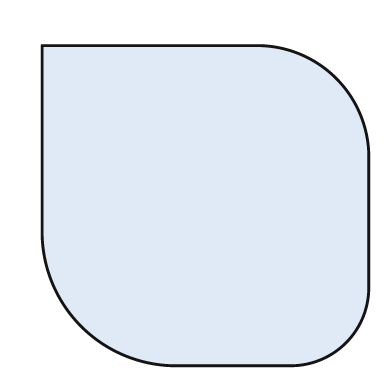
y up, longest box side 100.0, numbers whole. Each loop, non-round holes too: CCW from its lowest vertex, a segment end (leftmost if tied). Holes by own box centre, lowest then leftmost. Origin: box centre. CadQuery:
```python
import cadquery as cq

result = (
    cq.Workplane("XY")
    .moveTo(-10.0, -49.0)
    .lineTo(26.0, -49.0)
    .threePointArc((43.0, -42.0), (50.0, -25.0))
    .lineTo(50.0, 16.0)
    .threePointArc((40.0, 39.0), (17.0, 49.0))
    .lineTo(-50.0, 49.0)
    .lineTo(-50.0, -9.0)
    .threePointArc((-38.0, -37.0), (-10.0, -49.0))
    .close()
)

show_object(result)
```